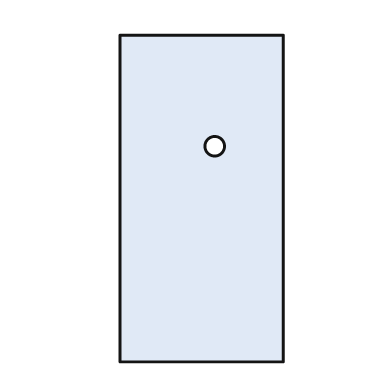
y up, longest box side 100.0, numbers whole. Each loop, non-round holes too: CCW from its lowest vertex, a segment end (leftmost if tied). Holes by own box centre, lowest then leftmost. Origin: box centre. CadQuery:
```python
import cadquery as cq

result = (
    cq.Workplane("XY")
    .moveTo(-25.0, -50.0)
    .lineTo(25.0, -50.0)
    .lineTo(25.0, 50.0)
    .lineTo(-25.0, 50.0)
    .close()
    .moveTo(4.0, 16.0)
    .circle(3.0)
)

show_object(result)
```